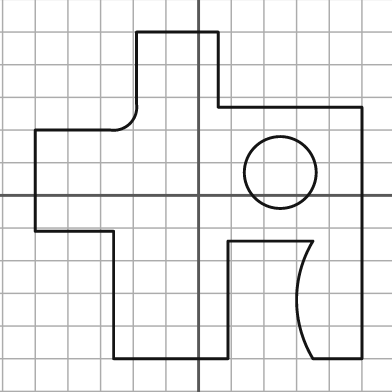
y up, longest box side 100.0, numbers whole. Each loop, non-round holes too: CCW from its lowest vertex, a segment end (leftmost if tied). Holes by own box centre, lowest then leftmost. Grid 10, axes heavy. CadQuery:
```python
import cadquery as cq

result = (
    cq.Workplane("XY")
    .moveTo(-26.0, -50.0)
    .lineTo(9.0, -50.0)
    .lineTo(9.0, -14.0)
    .lineTo(35.0, -14.0)
    .threePointArc((30.0, -32.0), (35.0, -50.0))
    .lineTo(50.0, -50.0)
    .lineTo(50.0, 27.0)
    .lineTo(6.0, 27.0)
    .lineTo(6.0, 50.0)
    .lineTo(-19.0, 50.0)
    .lineTo(-19.0, 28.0)
    .threePointArc((-21.0, 22.0), (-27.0, 20.0))
    .lineTo(-50.0, 20.0)
    .lineTo(-50.0, -11.0)
    .lineTo(-26.0, -11.0)
    .close()
    .moveTo(25.0, 7.0)
    .circle(11.0)
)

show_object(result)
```